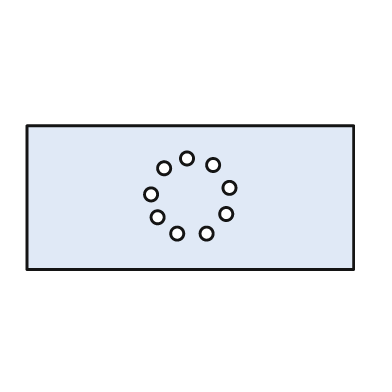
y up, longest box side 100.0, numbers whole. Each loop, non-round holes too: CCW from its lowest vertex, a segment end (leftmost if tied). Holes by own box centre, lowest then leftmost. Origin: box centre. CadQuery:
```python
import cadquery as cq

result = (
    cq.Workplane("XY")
    .moveTo(-50.0, -22.0)
    .lineTo(50.0, -22.0)
    .lineTo(50.0, 22.0)
    .lineTo(-50.0, 22.0)
    .close()
    .moveTo(-4.0, -11.0)
    .circle(2.0)
    .moveTo(5.0, -11.0)
    .circle(2.0)
    .moveTo(-10.0, -6.0)
    .circle(2.0)
    .moveTo(11.0, -5.0)
    .circle(2.0)
    .moveTo(-12.0, 1.0)
    .circle(2.0)
    .moveTo(12.0, 3.0)
    .circle(2.0)
    .moveTo(-8.0, 9.0)
    .circle(2.0)
    .moveTo(7.0, 10.0)
    .circle(2.0)
    .moveTo(-1.0, 12.0)
    .circle(2.0)
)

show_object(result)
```